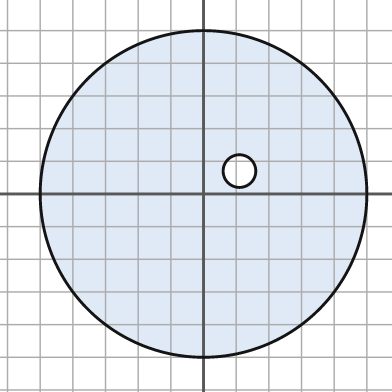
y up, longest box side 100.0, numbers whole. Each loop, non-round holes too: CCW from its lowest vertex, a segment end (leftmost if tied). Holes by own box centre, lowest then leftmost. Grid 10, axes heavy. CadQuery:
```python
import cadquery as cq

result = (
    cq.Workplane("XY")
    .moveTo(0.0, 0.0)
    .circle(50.0)
    .moveTo(11.0, 7.0)
    .circle(5.0)
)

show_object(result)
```